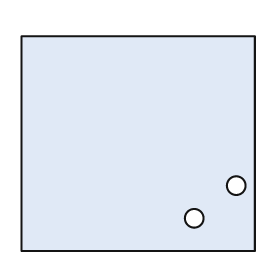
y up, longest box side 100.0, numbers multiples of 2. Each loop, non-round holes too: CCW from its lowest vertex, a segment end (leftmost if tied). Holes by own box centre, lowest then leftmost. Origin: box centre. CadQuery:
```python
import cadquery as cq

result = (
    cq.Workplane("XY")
    .moveTo(-50.0, -46.0)
    .lineTo(50.0, -46.0)
    .lineTo(50.0, 46.0)
    .lineTo(-50.0, 46.0)
    .close()
    .moveTo(24.0, -32.0)
    .circle(4.0)
    .moveTo(42.0, -18.0)
    .circle(4.0)
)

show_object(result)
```